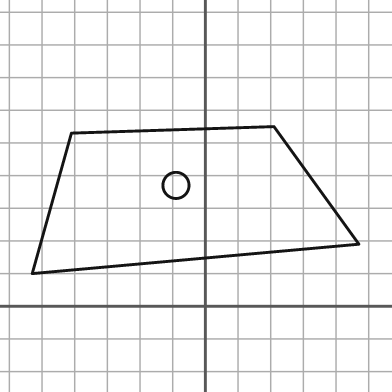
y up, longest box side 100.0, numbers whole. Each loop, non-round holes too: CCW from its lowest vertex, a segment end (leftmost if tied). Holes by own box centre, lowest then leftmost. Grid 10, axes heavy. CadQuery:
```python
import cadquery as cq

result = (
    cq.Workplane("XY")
    .moveTo(-53.0, 10.0)
    .lineTo(47.0, 19.0)
    .lineTo(21.0, 55.0)
    .lineTo(-41.0, 53.0)
    .close()
    .moveTo(-9.0, 37.0)
    .circle(4.0)
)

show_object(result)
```